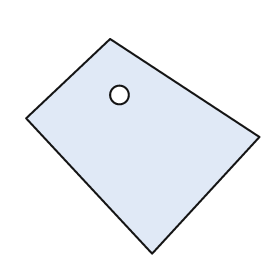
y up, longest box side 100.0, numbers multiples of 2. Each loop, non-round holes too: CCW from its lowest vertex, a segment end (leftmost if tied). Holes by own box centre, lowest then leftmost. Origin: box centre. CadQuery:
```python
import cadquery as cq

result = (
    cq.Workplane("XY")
    .moveTo(4.0, -46.0)
    .lineTo(50.0, 4.0)
    .lineTo(-14.0, 46.0)
    .lineTo(-50.0, 12.0)
    .close()
    .moveTo(-10.0, 22.0)
    .circle(4.0)
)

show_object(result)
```